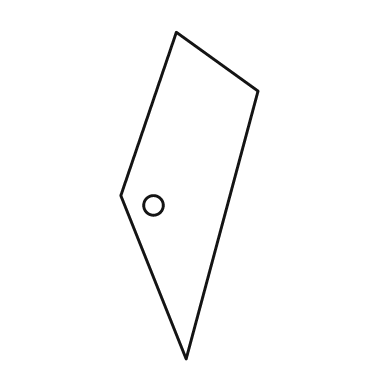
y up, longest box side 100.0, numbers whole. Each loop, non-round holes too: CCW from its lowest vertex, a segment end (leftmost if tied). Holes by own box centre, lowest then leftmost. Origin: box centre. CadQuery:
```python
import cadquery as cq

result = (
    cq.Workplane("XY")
    .moveTo(-1.0, -50.0)
    .lineTo(21.0, 32.0)
    .lineTo(-4.0, 50.0)
    .lineTo(-21.0, 0.0)
    .close()
    .moveTo(-11.0, -3.0)
    .circle(3.0)
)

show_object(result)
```